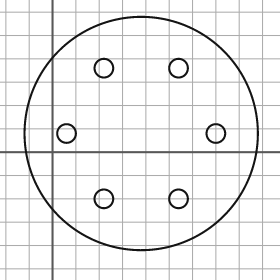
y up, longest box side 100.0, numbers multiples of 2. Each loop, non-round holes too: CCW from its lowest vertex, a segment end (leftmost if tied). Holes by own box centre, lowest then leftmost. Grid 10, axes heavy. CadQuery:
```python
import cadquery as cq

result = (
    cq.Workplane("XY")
    .moveTo(38.0, 8.0)
    .circle(50.0)
    .moveTo(22.0, -20.0)
    .circle(4.0)
    .moveTo(54.0, -20.0)
    .circle(4.0)
    .moveTo(6.0, 8.0)
    .circle(4.0)
    .moveTo(70.0, 8.0)
    .circle(4.0)
    .moveTo(22.0, 36.0)
    .circle(4.0)
    .moveTo(54.0, 36.0)
    .circle(4.0)
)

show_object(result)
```